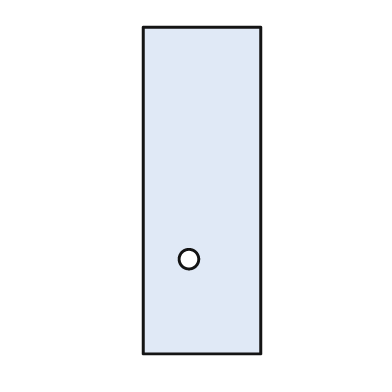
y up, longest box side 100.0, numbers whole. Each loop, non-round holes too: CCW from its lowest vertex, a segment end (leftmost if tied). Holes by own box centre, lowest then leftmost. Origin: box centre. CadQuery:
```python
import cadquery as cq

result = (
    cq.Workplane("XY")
    .moveTo(-18.0, -50.0)
    .lineTo(18.0, -50.0)
    .lineTo(18.0, 50.0)
    .lineTo(-18.0, 50.0)
    .close()
    .moveTo(-4.0, -21.0)
    .circle(3.0)
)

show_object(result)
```